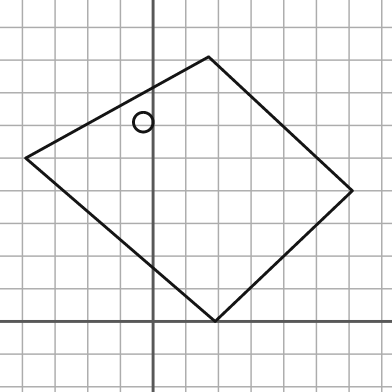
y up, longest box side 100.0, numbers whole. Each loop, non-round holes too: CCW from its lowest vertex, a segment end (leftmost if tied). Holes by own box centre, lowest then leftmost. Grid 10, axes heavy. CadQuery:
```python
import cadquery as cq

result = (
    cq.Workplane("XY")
    .moveTo(19.0, 0.0)
    .lineTo(61.0, 40.0)
    .lineTo(17.0, 81.0)
    .lineTo(-39.0, 50.0)
    .close()
    .moveTo(-3.0, 61.0)
    .circle(3.0)
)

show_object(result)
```